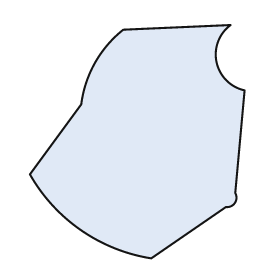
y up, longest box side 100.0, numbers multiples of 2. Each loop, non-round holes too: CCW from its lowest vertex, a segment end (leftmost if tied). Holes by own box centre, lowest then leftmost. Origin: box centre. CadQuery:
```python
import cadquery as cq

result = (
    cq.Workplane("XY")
    .moveTo(6.0, -50.0)
    .lineTo(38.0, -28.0)
    .threePointArc((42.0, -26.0), (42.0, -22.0))
    .lineTo(46.0, 22.0)
    .threePointArc((34.0, 34.0), (40.0, 50.0))
    .lineTo(-6.0, 48.0)
    .threePointArc((-18.0, 34.0), (-24.0, 16.0))
    .lineTo(-46.0, -14.0)
    .threePointArc((-24.0, -38.0), (6.0, -50.0))
    .close()
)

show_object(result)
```